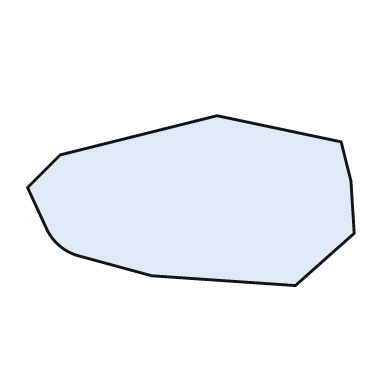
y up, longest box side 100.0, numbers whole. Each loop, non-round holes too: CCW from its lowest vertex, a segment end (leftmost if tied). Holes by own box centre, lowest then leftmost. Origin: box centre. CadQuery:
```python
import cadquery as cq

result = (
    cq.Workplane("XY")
    .moveTo(32.0, -26.0)
    .lineTo(50.0, -10.0)
    .lineTo(49.0, 6.0)
    .lineTo(46.0, 18.0)
    .lineTo(8.0, 26.0)
    .lineTo(-40.0, 14.0)
    .lineTo(-50.0, 4.0)
    .lineTo(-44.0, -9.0)
    .threePointArc((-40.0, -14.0), (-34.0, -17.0))
    .lineTo(-12.0, -23.0)
    .close()
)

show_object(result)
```